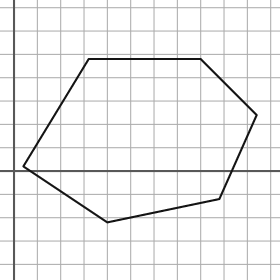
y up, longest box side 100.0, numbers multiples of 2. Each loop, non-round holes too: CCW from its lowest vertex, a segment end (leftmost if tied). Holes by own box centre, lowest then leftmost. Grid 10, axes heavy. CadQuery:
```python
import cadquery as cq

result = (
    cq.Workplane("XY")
    .moveTo(40.0, -22.0)
    .lineTo(88.0, -12.0)
    .lineTo(104.0, 24.0)
    .lineTo(80.0, 48.0)
    .lineTo(32.0, 48.0)
    .lineTo(4.0, 2.0)
    .close()
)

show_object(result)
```